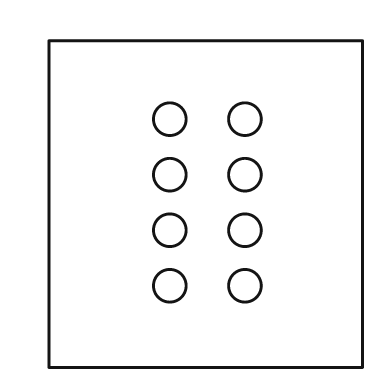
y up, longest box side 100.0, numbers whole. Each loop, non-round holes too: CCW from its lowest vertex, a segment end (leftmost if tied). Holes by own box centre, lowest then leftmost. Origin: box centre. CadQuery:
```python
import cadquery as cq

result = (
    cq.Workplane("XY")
    .moveTo(-48.0, -50.0)
    .lineTo(48.0, -50.0)
    .lineTo(48.0, 50.0)
    .lineTo(-48.0, 50.0)
    .close()
    .moveTo(-11.0, -25.0)
    .circle(5.0)
    .moveTo(12.0, -25.0)
    .circle(5.0)
    .moveTo(-11.0, -8.0)
    .circle(5.0)
    .moveTo(12.0, -8.0)
    .circle(5.0)
    .moveTo(-11.0, 9.0)
    .circle(5.0)
    .moveTo(12.0, 9.0)
    .circle(5.0)
    .moveTo(-11.0, 26.0)
    .circle(5.0)
    .moveTo(12.0, 26.0)
    .circle(5.0)
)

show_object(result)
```